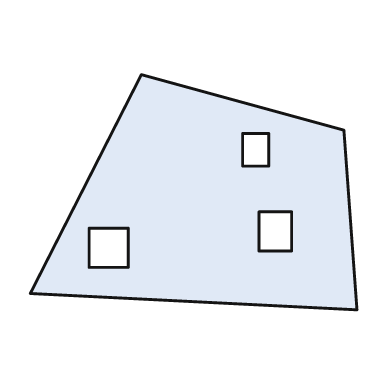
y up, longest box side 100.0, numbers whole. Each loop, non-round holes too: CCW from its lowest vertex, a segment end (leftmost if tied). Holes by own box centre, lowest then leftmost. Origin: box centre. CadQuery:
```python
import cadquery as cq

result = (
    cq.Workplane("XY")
    .moveTo(50.0, -36.0)
    .lineTo(46.0, 19.0)
    .lineTo(-16.0, 36.0)
    .lineTo(-50.0, -31.0)
    .close()
    .moveTo(-32.0, -23.0)
    .lineTo(-20.0, -23.0)
    .lineTo(-20.0, -11.0)
    .lineTo(-32.0, -11.0)
    .close()
    .moveTo(20.0, -18.0)
    .lineTo(30.0, -18.0)
    .lineTo(30.0, -6.0)
    .lineTo(20.0, -6.0)
    .close()
    .moveTo(15.0, 8.0)
    .lineTo(23.0, 8.0)
    .lineTo(23.0, 18.0)
    .lineTo(15.0, 18.0)
    .close()
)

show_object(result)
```